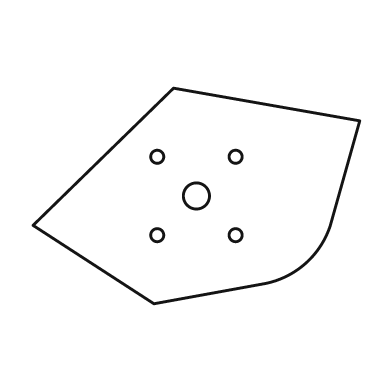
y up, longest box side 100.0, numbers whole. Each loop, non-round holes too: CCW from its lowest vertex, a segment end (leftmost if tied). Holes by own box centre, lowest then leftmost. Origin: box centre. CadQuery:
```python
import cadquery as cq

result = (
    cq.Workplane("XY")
    .moveTo(-13.0, -33.0)
    .lineTo(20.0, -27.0)
    .threePointArc((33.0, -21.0), (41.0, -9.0))
    .lineTo(50.0, 23.0)
    .lineTo(-7.0, 33.0)
    .lineTo(-50.0, -9.0)
    .close()
    .moveTo(-12.0, -12.0)
    .circle(2.0)
    .moveTo(12.0, -12.0)
    .circle(2.0)
    .moveTo(0.0, 0.0)
    .circle(4.0)
    .moveTo(-12.0, 12.0)
    .circle(2.0)
    .moveTo(12.0, 12.0)
    .circle(2.0)
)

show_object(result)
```